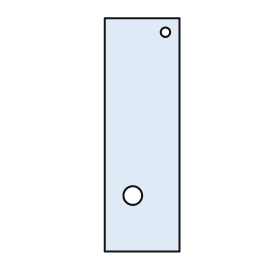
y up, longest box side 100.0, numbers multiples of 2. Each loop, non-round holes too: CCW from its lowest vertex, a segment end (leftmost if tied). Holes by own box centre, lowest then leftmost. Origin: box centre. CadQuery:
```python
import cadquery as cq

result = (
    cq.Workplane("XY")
    .moveTo(-16.0, -50.0)
    .lineTo(16.0, -50.0)
    .lineTo(16.0, 50.0)
    .lineTo(-16.0, 50.0)
    .close()
    .moveTo(-4.0, -26.0)
    .circle(4.0)
    .moveTo(10.0, 44.0)
    .circle(2.0)
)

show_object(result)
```